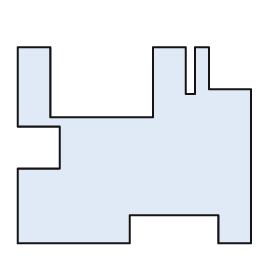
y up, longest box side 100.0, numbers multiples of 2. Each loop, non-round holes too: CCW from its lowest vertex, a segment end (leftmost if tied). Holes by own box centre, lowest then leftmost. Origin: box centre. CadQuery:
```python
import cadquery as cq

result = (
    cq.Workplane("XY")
    .moveTo(-50.0, -42.0)
    .lineTo(-2.0, -42.0)
    .lineTo(-2.0, -30.0)
    .lineTo(36.0, -30.0)
    .lineTo(36.0, -42.0)
    .lineTo(50.0, -42.0)
    .lineTo(50.0, 24.0)
    .lineTo(32.0, 24.0)
    .lineTo(32.0, 42.0)
    .lineTo(26.0, 42.0)
    .lineTo(26.0, 22.0)
    .lineTo(22.0, 22.0)
    .lineTo(22.0, 42.0)
    .lineTo(8.0, 42.0)
    .lineTo(8.0, 12.0)
    .lineTo(-36.0, 12.0)
    .lineTo(-36.0, 42.0)
    .lineTo(-50.0, 42.0)
    .lineTo(-50.0, 8.0)
    .lineTo(-32.0, 8.0)
    .lineTo(-32.0, -10.0)
    .lineTo(-50.0, -10.0)
    .close()
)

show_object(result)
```